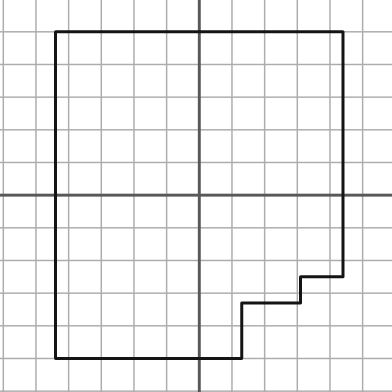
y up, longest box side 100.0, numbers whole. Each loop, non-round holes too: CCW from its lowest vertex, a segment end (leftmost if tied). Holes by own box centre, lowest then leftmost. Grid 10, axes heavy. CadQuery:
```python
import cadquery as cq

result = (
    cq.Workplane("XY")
    .moveTo(-44.0, -50.0)
    .lineTo(13.0, -50.0)
    .lineTo(13.0, -33.0)
    .lineTo(31.0, -33.0)
    .lineTo(31.0, -25.0)
    .lineTo(44.0, -25.0)
    .lineTo(44.0, 50.0)
    .lineTo(-44.0, 50.0)
    .close()
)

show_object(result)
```